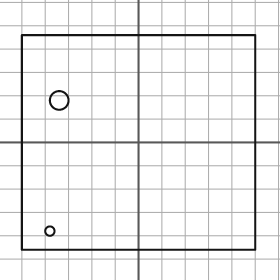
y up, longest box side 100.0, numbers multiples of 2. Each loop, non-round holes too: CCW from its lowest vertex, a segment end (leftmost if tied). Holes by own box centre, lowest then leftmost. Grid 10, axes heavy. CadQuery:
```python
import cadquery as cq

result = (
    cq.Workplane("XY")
    .moveTo(-50.0, -46.0)
    .lineTo(50.0, -46.0)
    .lineTo(50.0, 46.0)
    .lineTo(-50.0, 46.0)
    .close()
    .moveTo(-38.0, -38.0)
    .circle(2.0)
    .moveTo(-34.0, 18.0)
    .circle(4.0)
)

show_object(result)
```